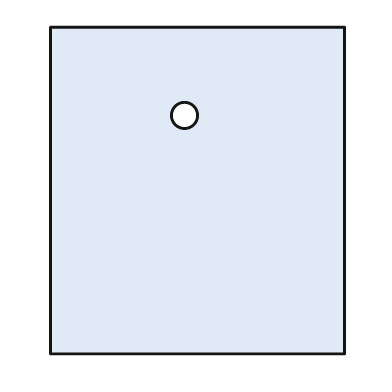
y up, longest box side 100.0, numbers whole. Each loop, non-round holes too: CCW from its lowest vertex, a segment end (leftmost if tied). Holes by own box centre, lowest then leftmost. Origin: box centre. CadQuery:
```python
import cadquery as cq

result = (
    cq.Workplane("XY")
    .moveTo(-45.0, -50.0)
    .lineTo(45.0, -50.0)
    .lineTo(45.0, 50.0)
    .lineTo(-45.0, 50.0)
    .close()
    .moveTo(-4.0, 23.0)
    .circle(4.0)
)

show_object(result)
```